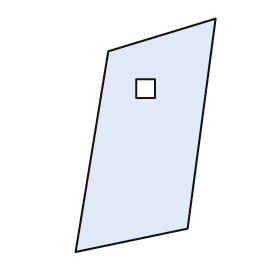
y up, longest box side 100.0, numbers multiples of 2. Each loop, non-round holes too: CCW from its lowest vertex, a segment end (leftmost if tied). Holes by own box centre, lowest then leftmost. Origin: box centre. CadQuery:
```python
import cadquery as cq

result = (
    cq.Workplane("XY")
    .moveTo(-30.0, -50.0)
    .lineTo(18.0, -40.0)
    .lineTo(30.0, 50.0)
    .lineTo(-16.0, 36.0)
    .close()
    .moveTo(-4.0, 16.0)
    .lineTo(4.0, 16.0)
    .lineTo(4.0, 24.0)
    .lineTo(-4.0, 24.0)
    .close()
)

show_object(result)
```